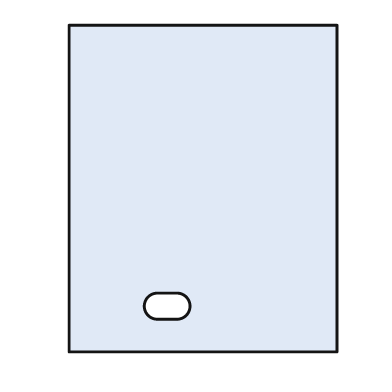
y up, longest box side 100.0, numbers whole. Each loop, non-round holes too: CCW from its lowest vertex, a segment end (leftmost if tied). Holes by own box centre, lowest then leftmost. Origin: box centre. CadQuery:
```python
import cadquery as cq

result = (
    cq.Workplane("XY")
    .moveTo(-41.0, -50.0)
    .lineTo(41.0, -50.0)
    .lineTo(41.0, 50.0)
    .lineTo(-41.0, 50.0)
    .close()
    .moveTo(-14.0, -40.0)
    .lineTo(-8.0, -40.0)
    .threePointArc((-4.0, -36.0), (-8.0, -32.0))
    .lineTo(-14.0, -32.0)
    .threePointArc((-18.0, -36.0), (-14.0, -40.0))
    .close()
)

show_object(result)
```